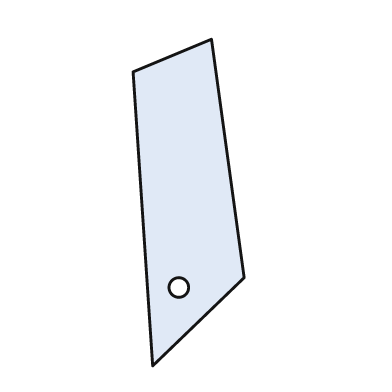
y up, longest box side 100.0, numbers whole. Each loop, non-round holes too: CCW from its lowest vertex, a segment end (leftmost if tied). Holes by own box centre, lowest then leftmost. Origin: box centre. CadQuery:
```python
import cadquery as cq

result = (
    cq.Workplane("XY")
    .moveTo(-11.0, -50.0)
    .lineTo(17.0, -23.0)
    .lineTo(7.0, 50.0)
    .lineTo(-17.0, 40.0)
    .close()
    .moveTo(-3.0, -26.0)
    .circle(3.0)
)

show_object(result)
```